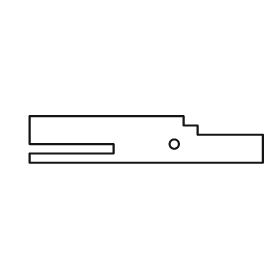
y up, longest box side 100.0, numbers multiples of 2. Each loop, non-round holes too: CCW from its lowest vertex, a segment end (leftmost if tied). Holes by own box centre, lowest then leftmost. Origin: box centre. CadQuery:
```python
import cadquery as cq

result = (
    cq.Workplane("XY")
    .moveTo(-50.0, -10.0)
    .lineTo(50.0, -10.0)
    .lineTo(50.0, 2.0)
    .lineTo(22.0, 2.0)
    .lineTo(22.0, 6.0)
    .lineTo(16.0, 6.0)
    .lineTo(16.0, 10.0)
    .lineTo(-50.0, 10.0)
    .lineTo(-50.0, -2.0)
    .lineTo(-14.0, -2.0)
    .lineTo(-14.0, -6.0)
    .lineTo(-50.0, -6.0)
    .close()
    .moveTo(12.0, -2.0)
    .circle(2.0)
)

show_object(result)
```